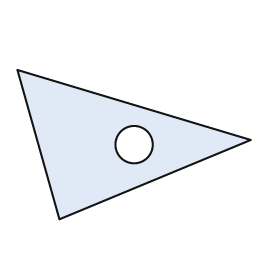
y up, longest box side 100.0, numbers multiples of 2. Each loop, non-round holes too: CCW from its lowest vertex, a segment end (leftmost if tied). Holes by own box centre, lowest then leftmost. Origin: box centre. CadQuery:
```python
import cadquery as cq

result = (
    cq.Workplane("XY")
    .moveTo(-32.0, -32.0)
    .lineTo(50.0, 2.0)
    .lineTo(-50.0, 32.0)
    .close()
    .moveTo(0.0, 0.0)
    .circle(8.0)
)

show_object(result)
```